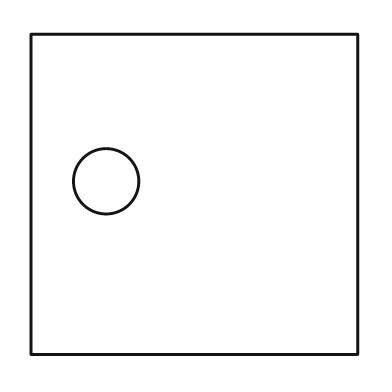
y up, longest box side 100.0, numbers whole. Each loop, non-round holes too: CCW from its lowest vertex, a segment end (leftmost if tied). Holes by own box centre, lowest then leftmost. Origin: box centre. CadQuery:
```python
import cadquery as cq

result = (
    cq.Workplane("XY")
    .moveTo(-50.0, -49.0)
    .lineTo(50.0, -49.0)
    .lineTo(50.0, 49.0)
    .lineTo(-50.0, 49.0)
    .close()
    .moveTo(-27.0, 4.0)
    .circle(10.0)
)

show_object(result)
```